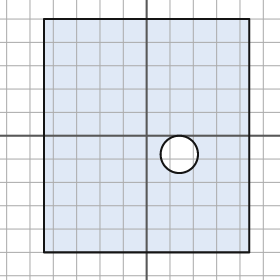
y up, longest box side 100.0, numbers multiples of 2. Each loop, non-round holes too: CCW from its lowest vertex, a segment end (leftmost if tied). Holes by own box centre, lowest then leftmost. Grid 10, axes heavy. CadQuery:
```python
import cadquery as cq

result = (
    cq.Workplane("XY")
    .moveTo(-44.0, -50.0)
    .lineTo(44.0, -50.0)
    .lineTo(44.0, 50.0)
    .lineTo(-44.0, 50.0)
    .close()
    .moveTo(14.0, -8.0)
    .circle(8.0)
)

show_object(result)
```